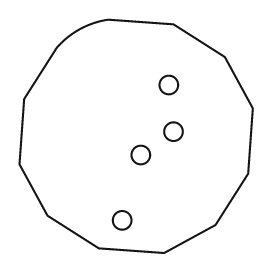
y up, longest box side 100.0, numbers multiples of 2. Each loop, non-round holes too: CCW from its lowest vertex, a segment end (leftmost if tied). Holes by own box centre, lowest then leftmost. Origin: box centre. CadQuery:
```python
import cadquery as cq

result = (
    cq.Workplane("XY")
    .moveTo(12.0, -50.0)
    .lineTo(34.0, -38.0)
    .lineTo(48.0, -16.0)
    .lineTo(50.0, 12.0)
    .lineTo(38.0, 34.0)
    .lineTo(16.0, 48.0)
    .lineTo(-12.0, 50.0)
    .threePointArc((-24.0, 46.0), (-34.0, 38.0))
    .lineTo(-48.0, 16.0)
    .lineTo(-50.0, -12.0)
    .lineTo(-38.0, -34.0)
    .lineTo(-16.0, -48.0)
    .close()
    .moveTo(-6.0, -36.0)
    .circle(4.0)
    .moveTo(2.0, -8.0)
    .circle(4.0)
    .moveTo(16.0, 2.0)
    .circle(4.0)
    .moveTo(14.0, 22.0)
    .circle(4.0)
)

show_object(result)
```